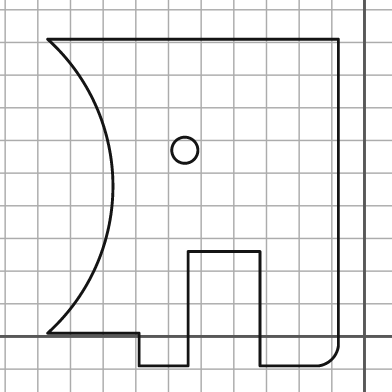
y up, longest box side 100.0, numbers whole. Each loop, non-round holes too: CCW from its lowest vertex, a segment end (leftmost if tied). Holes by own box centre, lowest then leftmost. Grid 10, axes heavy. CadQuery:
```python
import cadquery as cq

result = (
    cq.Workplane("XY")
    .moveTo(-69.0, -9.0)
    .lineTo(-54.0, -9.0)
    .lineTo(-54.0, 26.0)
    .lineTo(-32.0, 26.0)
    .lineTo(-32.0, -9.0)
    .lineTo(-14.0, -9.0)
    .threePointArc((-10.0, -7.0), (-8.0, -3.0))
    .lineTo(-8.0, 91.0)
    .lineTo(-97.0, 91.0)
    .threePointArc((-77.0, 46.0), (-97.0, 1.0))
    .lineTo(-69.0, 1.0)
    .close()
    .moveTo(-55.0, 57.0)
    .circle(4.0)
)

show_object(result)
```